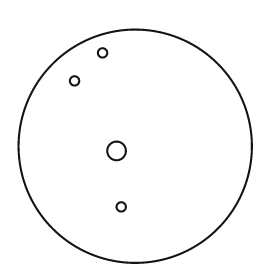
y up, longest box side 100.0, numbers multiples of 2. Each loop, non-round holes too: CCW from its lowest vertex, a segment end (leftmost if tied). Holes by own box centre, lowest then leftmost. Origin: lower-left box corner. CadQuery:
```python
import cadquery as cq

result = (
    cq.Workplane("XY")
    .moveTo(50.0, 50.0)
    .circle(50.0)
    .moveTo(44.0, 24.0)
    .circle(2.0)
    .moveTo(42.0, 48.0)
    .circle(4.0)
    .moveTo(24.0, 78.0)
    .circle(2.0)
    .moveTo(36.0, 90.0)
    .circle(2.0)
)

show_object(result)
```